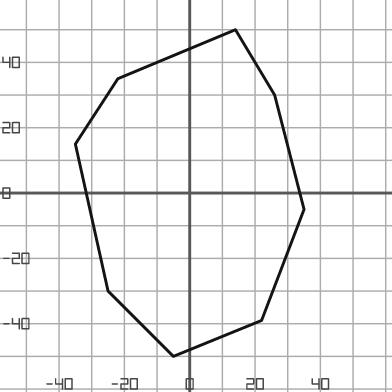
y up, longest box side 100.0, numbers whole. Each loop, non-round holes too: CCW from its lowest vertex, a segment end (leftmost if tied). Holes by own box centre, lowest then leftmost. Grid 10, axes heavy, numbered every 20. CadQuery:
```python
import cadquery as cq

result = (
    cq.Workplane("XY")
    .moveTo(-5.0, -50.0)
    .lineTo(22.0, -39.0)
    .lineTo(35.0, -5.0)
    .lineTo(26.0, 30.0)
    .lineTo(14.0, 50.0)
    .lineTo(-22.0, 35.0)
    .lineTo(-35.0, 15.0)
    .lineTo(-25.0, -30.0)
    .close()
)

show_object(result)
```